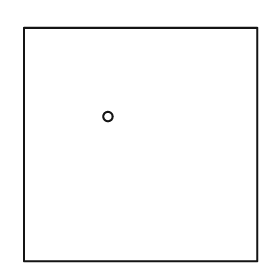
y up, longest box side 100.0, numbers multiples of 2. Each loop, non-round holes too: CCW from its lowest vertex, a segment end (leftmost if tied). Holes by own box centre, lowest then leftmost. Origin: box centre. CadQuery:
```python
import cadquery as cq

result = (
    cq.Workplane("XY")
    .moveTo(-50.0, -50.0)
    .lineTo(50.0, -50.0)
    .lineTo(50.0, 50.0)
    .lineTo(-50.0, 50.0)
    .close()
    .moveTo(-14.0, 12.0)
    .circle(2.0)
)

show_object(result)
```